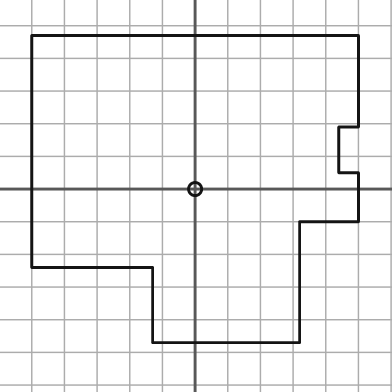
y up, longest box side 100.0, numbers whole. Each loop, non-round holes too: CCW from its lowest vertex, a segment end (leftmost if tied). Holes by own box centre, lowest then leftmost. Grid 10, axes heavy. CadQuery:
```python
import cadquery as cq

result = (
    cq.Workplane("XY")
    .moveTo(-13.0, -47.0)
    .lineTo(32.0, -47.0)
    .lineTo(32.0, -10.0)
    .lineTo(50.0, -10.0)
    .lineTo(50.0, 5.0)
    .lineTo(44.0, 5.0)
    .lineTo(44.0, 19.0)
    .lineTo(50.0, 19.0)
    .lineTo(50.0, 47.0)
    .lineTo(-50.0, 47.0)
    .lineTo(-50.0, -24.0)
    .lineTo(-13.0, -24.0)
    .close()
    .moveTo(0.0, 0.0)
    .circle(2.0)
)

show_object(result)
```